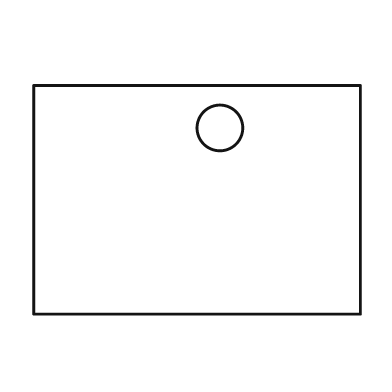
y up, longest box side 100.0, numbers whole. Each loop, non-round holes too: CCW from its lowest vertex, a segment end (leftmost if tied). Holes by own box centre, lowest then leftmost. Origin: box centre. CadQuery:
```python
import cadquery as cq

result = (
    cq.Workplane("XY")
    .moveTo(-50.0, -35.0)
    .lineTo(50.0, -35.0)
    .lineTo(50.0, 35.0)
    .lineTo(-50.0, 35.0)
    .close()
    .moveTo(7.0, 22.0)
    .circle(7.0)
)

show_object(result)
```